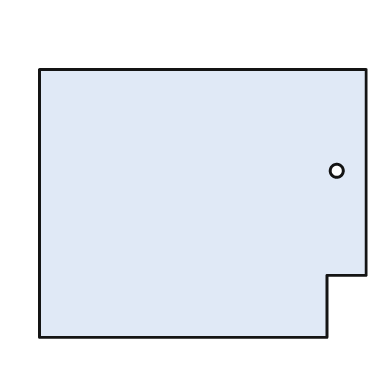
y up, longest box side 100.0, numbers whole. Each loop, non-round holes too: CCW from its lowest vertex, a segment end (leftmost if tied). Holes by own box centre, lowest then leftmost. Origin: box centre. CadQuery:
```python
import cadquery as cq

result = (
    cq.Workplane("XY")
    .moveTo(-50.0, -41.0)
    .lineTo(38.0, -41.0)
    .lineTo(38.0, -22.0)
    .lineTo(50.0, -22.0)
    .lineTo(50.0, 41.0)
    .lineTo(-50.0, 41.0)
    .close()
    .moveTo(41.0, 10.0)
    .circle(2.0)
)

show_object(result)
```